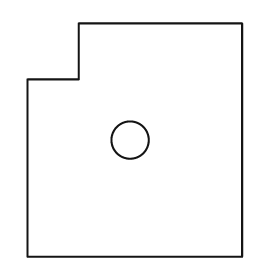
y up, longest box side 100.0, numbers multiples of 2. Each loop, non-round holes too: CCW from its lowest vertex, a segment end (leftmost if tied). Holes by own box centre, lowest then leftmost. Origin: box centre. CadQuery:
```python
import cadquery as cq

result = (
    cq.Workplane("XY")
    .moveTo(-46.0, -50.0)
    .lineTo(46.0, -50.0)
    .lineTo(46.0, 50.0)
    .lineTo(-24.0, 50.0)
    .lineTo(-24.0, 26.0)
    .lineTo(-46.0, 26.0)
    .close()
    .moveTo(-2.0, 0.0)
    .circle(8.0)
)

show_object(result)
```